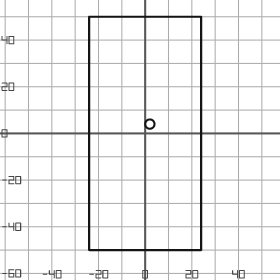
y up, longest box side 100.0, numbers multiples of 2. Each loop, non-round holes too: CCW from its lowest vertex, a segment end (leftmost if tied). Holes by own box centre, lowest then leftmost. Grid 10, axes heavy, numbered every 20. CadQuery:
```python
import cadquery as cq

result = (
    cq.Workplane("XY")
    .moveTo(-24.0, -50.0)
    .lineTo(24.0, -50.0)
    .lineTo(24.0, 50.0)
    .lineTo(-24.0, 50.0)
    .close()
    .moveTo(2.0, 4.0)
    .circle(2.0)
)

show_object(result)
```